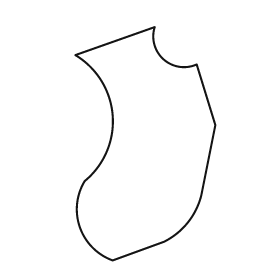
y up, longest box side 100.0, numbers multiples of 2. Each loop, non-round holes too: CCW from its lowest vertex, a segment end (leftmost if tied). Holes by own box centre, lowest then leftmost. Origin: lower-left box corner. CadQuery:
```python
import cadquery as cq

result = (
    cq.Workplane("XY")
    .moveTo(16.0, 0.0)
    .lineTo(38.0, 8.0)
    .threePointArc((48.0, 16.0), (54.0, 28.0))
    .lineTo(60.0, 58.0)
    .lineTo(52.0, 84.0)
    .threePointArc((38.0, 86.0), (34.0, 100.0))
    .lineTo(0.0, 88.0)
    .threePointArc((16.0, 62.0), (4.0, 34.0))
    .threePointArc((2.0, 14.0), (16.0, 0.0))
    .close()
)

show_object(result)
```